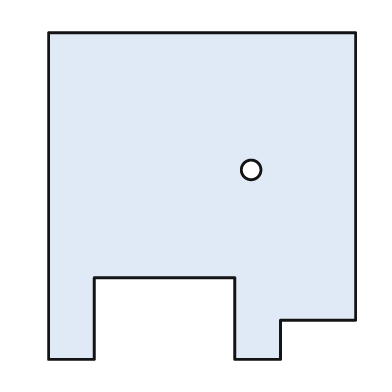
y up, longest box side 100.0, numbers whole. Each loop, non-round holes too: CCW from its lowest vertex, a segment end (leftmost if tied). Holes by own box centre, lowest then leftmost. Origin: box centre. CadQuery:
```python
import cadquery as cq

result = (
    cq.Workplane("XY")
    .moveTo(-47.0, -50.0)
    .lineTo(-33.0, -50.0)
    .lineTo(-33.0, -25.0)
    .lineTo(10.0, -25.0)
    .lineTo(10.0, -50.0)
    .lineTo(24.0, -50.0)
    .lineTo(24.0, -38.0)
    .lineTo(47.0, -38.0)
    .lineTo(47.0, 50.0)
    .lineTo(-47.0, 50.0)
    .close()
    .moveTo(15.0, 8.0)
    .circle(3.0)
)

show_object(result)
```